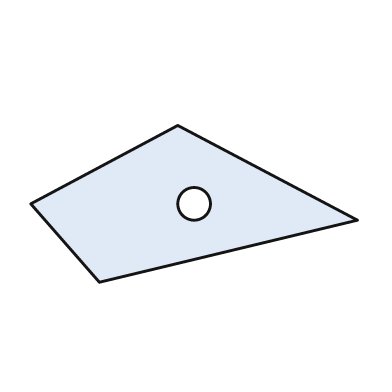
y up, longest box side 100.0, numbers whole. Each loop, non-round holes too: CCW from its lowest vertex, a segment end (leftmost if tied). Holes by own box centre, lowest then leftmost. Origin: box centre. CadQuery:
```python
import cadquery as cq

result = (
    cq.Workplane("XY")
    .moveTo(-29.0, -24.0)
    .lineTo(50.0, -5.0)
    .lineTo(-5.0, 24.0)
    .lineTo(-50.0, 0.0)
    .close()
    .moveTo(0.0, 0.0)
    .circle(5.0)
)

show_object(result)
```